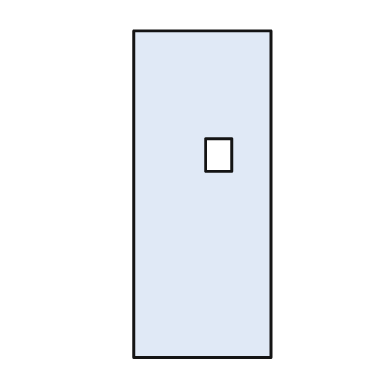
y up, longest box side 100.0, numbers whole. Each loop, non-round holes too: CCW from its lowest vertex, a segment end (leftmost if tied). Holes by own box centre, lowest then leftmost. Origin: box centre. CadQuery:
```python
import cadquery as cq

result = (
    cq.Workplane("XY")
    .moveTo(-21.0, -50.0)
    .lineTo(21.0, -50.0)
    .lineTo(21.0, 50.0)
    .lineTo(-21.0, 50.0)
    .close()
    .moveTo(1.0, 7.0)
    .lineTo(9.0, 7.0)
    .lineTo(9.0, 17.0)
    .lineTo(1.0, 17.0)
    .close()
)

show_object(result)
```